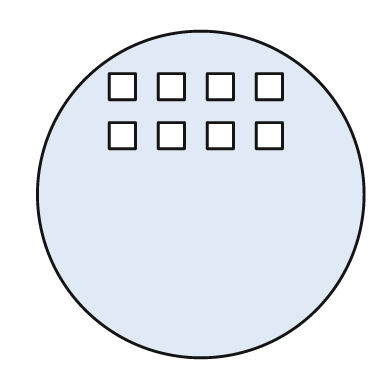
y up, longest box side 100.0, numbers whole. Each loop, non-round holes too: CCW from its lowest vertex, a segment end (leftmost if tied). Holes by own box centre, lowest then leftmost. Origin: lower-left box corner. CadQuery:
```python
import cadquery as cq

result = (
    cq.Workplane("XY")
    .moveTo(50.0, 50.0)
    .circle(50.0)
    .moveTo(22.0, 64.0)
    .lineTo(30.0, 64.0)
    .lineTo(30.0, 72.0)
    .lineTo(22.0, 72.0)
    .close()
    .moveTo(37.0, 64.0)
    .lineTo(45.0, 64.0)
    .lineTo(45.0, 72.0)
    .lineTo(37.0, 72.0)
    .close()
    .moveTo(52.0, 64.0)
    .lineTo(60.0, 64.0)
    .lineTo(60.0, 72.0)
    .lineTo(52.0, 72.0)
    .close()
    .moveTo(67.0, 64.0)
    .lineTo(75.0, 64.0)
    .lineTo(75.0, 72.0)
    .lineTo(67.0, 72.0)
    .close()
    .moveTo(22.0, 79.0)
    .lineTo(30.0, 79.0)
    .lineTo(30.0, 87.0)
    .lineTo(22.0, 87.0)
    .close()
    .moveTo(37.0, 79.0)
    .lineTo(45.0, 79.0)
    .lineTo(45.0, 87.0)
    .lineTo(37.0, 87.0)
    .close()
    .moveTo(52.0, 79.0)
    .lineTo(60.0, 79.0)
    .lineTo(60.0, 87.0)
    .lineTo(52.0, 87.0)
    .close()
    .moveTo(67.0, 79.0)
    .lineTo(75.0, 79.0)
    .lineTo(75.0, 87.0)
    .lineTo(67.0, 87.0)
    .close()
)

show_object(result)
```